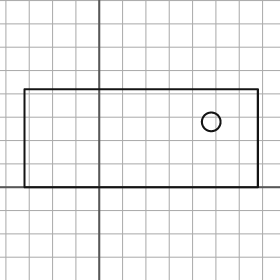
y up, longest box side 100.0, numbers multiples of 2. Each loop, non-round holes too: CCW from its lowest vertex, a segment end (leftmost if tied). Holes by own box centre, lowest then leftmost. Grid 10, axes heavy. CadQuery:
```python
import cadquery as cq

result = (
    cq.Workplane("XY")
    .moveTo(-32.0, 0.0)
    .lineTo(68.0, 0.0)
    .lineTo(68.0, 42.0)
    .lineTo(-32.0, 42.0)
    .close()
    .moveTo(48.0, 28.0)
    .circle(4.0)
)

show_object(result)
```